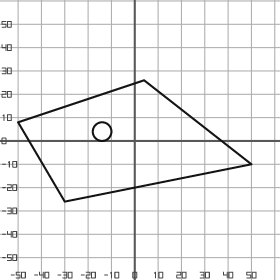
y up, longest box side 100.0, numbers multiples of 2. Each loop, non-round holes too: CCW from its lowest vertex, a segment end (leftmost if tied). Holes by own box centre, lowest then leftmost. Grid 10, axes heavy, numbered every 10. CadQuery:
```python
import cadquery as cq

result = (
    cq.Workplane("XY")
    .moveTo(-30.0, -26.0)
    .lineTo(50.0, -10.0)
    .lineTo(4.0, 26.0)
    .lineTo(-50.0, 8.0)
    .close()
    .moveTo(-14.0, 4.0)
    .circle(4.0)
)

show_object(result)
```